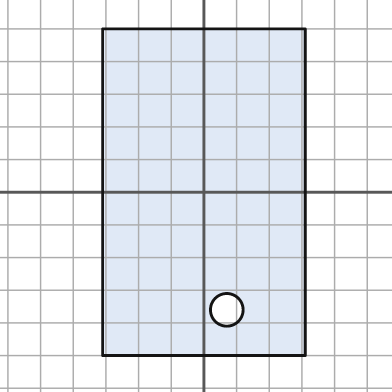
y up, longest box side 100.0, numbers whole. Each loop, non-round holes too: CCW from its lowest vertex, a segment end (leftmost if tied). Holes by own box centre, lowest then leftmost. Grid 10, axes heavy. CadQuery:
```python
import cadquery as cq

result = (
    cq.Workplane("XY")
    .moveTo(-31.0, -50.0)
    .lineTo(31.0, -50.0)
    .lineTo(31.0, 50.0)
    .lineTo(-31.0, 50.0)
    .close()
    .moveTo(7.0, -36.0)
    .circle(5.0)
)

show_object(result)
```